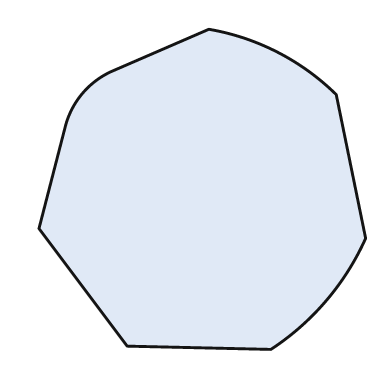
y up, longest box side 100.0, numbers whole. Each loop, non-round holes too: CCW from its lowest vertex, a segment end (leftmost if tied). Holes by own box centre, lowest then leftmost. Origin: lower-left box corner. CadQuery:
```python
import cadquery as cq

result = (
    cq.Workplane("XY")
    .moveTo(71.0, 0.0)
    .threePointArc((88.0, 15.0), (100.0, 34.0))
    .lineTo(91.0, 78.0)
    .threePointArc((73.0, 91.0), (52.0, 98.0))
    .lineTo(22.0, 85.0)
    .threePointArc((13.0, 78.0), (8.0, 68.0))
    .lineTo(0.0, 37.0)
    .lineTo(27.0, 1.0)
    .close()
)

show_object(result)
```